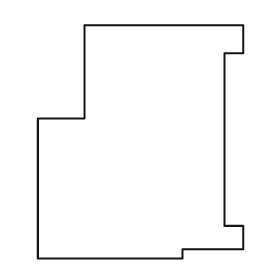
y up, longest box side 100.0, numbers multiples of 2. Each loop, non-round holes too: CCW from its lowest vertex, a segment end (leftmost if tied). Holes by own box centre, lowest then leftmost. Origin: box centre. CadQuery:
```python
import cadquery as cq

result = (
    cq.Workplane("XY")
    .moveTo(-44.0, -50.0)
    .lineTo(18.0, -50.0)
    .lineTo(18.0, -46.0)
    .lineTo(44.0, -46.0)
    .lineTo(44.0, -36.0)
    .lineTo(36.0, -36.0)
    .lineTo(36.0, 38.0)
    .lineTo(44.0, 38.0)
    .lineTo(44.0, 50.0)
    .lineTo(-24.0, 50.0)
    .lineTo(-24.0, 10.0)
    .lineTo(-44.0, 10.0)
    .close()
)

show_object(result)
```